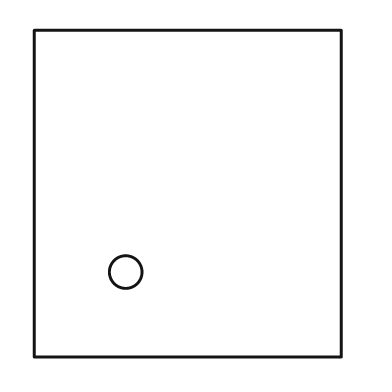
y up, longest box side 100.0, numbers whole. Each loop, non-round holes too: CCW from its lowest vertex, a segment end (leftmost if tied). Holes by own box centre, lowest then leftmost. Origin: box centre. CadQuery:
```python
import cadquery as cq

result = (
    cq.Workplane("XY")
    .moveTo(-47.0, -50.0)
    .lineTo(47.0, -50.0)
    .lineTo(47.0, 50.0)
    .lineTo(-47.0, 50.0)
    .close()
    .moveTo(-19.0, -24.0)
    .circle(5.0)
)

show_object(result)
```